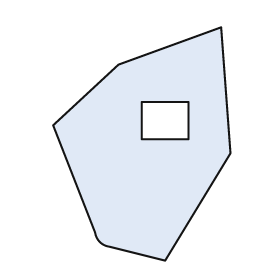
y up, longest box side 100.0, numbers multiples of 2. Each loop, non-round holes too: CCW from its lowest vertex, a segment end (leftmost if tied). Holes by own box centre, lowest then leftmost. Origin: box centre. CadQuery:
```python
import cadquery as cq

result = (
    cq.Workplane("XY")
    .moveTo(10.0, -50.0)
    .lineTo(38.0, -4.0)
    .lineTo(34.0, 50.0)
    .lineTo(-10.0, 34.0)
    .lineTo(-38.0, 8.0)
    .lineTo(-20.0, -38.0)
    .threePointArc((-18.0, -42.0), (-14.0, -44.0))
    .close()
    .moveTo(0.0, 2.0)
    .lineTo(20.0, 2.0)
    .lineTo(20.0, 18.0)
    .lineTo(0.0, 18.0)
    .close()
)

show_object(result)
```